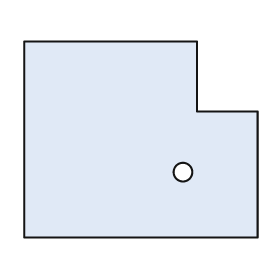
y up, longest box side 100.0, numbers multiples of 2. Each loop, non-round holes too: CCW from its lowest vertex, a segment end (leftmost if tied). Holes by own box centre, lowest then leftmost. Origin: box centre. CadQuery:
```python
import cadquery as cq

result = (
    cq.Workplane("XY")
    .moveTo(-50.0, -42.0)
    .lineTo(50.0, -42.0)
    .lineTo(50.0, 12.0)
    .lineTo(24.0, 12.0)
    .lineTo(24.0, 42.0)
    .lineTo(-50.0, 42.0)
    .close()
    .moveTo(18.0, -14.0)
    .circle(4.0)
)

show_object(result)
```